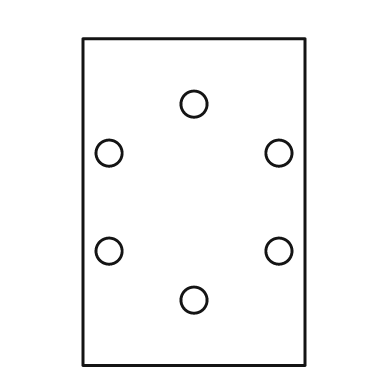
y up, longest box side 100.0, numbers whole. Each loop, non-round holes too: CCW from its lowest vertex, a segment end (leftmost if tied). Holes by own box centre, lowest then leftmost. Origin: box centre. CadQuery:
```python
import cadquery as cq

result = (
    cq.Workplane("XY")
    .moveTo(-34.0, -50.0)
    .lineTo(34.0, -50.0)
    .lineTo(34.0, 50.0)
    .lineTo(-34.0, 50.0)
    .close()
    .moveTo(0.0, -30.0)
    .circle(4.0)
    .moveTo(-26.0, -15.0)
    .circle(4.0)
    .moveTo(26.0, -15.0)
    .circle(4.0)
    .moveTo(-26.0, 15.0)
    .circle(4.0)
    .moveTo(26.0, 15.0)
    .circle(4.0)
    .moveTo(0.0, 30.0)
    .circle(4.0)
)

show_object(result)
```